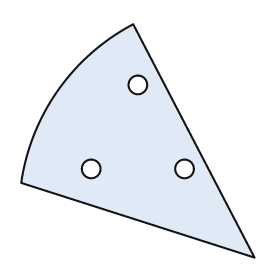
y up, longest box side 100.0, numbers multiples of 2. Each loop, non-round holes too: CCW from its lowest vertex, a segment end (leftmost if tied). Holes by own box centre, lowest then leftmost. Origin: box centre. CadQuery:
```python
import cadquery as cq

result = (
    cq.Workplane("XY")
    .moveTo(50.0, -50.0)
    .lineTo(-2.0, 50.0)
    .threePointArc((-34.0, 22.0), (-50.0, -18.0))
    .close()
    .moveTo(-20.0, -12.0)
    .circle(4.0)
    .moveTo(20.0, -12.0)
    .circle(4.0)
    .moveTo(0.0, 24.0)
    .circle(4.0)
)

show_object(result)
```